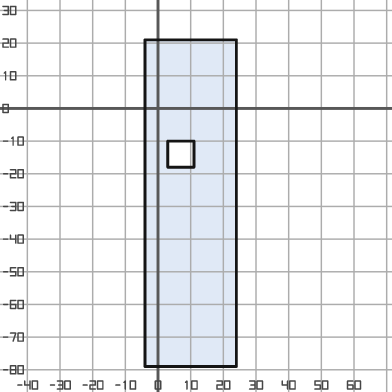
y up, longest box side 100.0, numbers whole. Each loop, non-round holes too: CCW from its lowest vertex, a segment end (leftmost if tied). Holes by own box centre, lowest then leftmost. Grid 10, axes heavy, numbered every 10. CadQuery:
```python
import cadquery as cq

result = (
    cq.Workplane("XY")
    .moveTo(-4.0, -79.0)
    .lineTo(24.0, -79.0)
    .lineTo(24.0, 21.0)
    .lineTo(-4.0, 21.0)
    .close()
    .moveTo(3.0, -18.0)
    .lineTo(11.0, -18.0)
    .lineTo(11.0, -10.0)
    .lineTo(3.0, -10.0)
    .close()
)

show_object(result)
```